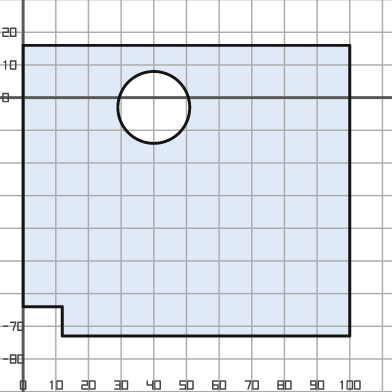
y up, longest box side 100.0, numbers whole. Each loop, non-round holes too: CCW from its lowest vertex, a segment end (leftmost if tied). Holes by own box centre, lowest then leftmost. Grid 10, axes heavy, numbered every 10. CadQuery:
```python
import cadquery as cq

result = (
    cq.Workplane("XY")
    .moveTo(12.0, -73.0)
    .lineTo(100.0, -73.0)
    .lineTo(100.0, 16.0)
    .lineTo(0.0, 16.0)
    .lineTo(0.0, -64.0)
    .lineTo(12.0, -64.0)
    .close()
    .moveTo(40.0, -3.0)
    .circle(11.0)
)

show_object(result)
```